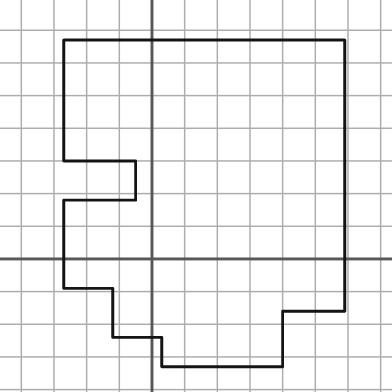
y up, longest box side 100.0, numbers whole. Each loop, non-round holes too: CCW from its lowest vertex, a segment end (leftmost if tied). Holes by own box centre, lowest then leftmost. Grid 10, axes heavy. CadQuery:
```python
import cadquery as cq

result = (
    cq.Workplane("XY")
    .moveTo(3.0, -33.0)
    .lineTo(40.0, -33.0)
    .lineTo(40.0, -16.0)
    .lineTo(59.0, -16.0)
    .lineTo(59.0, 67.0)
    .lineTo(-27.0, 67.0)
    .lineTo(-27.0, 30.0)
    .lineTo(-5.0, 30.0)
    .lineTo(-5.0, 18.0)
    .lineTo(-27.0, 18.0)
    .lineTo(-27.0, -9.0)
    .lineTo(-12.0, -9.0)
    .lineTo(-12.0, -24.0)
    .lineTo(3.0, -24.0)
    .close()
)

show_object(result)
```